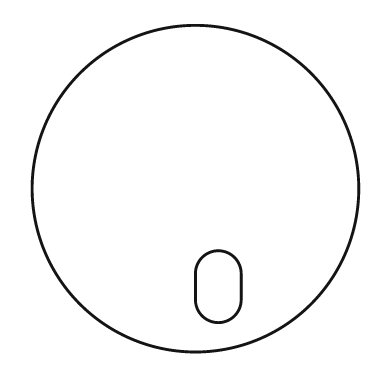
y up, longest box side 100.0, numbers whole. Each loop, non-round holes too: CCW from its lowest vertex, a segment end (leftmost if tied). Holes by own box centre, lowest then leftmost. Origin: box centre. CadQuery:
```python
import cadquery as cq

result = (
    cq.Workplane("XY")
    .moveTo(0.0, 0.0)
    .circle(50.0)
    .moveTo(0.0, -34.0)
    .threePointArc((7.0, -41.0), (14.0, -34.0))
    .lineTo(14.0, -26.0)
    .threePointArc((7.0, -19.0), (0.0, -26.0))
    .close()
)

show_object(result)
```